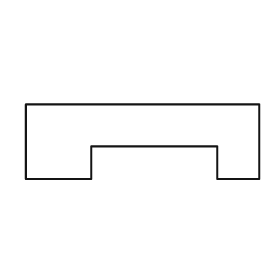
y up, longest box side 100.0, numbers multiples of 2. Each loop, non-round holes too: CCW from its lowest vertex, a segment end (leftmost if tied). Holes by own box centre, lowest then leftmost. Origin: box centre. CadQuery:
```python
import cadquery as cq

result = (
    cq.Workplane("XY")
    .moveTo(-50.0, -16.0)
    .lineTo(-22.0, -16.0)
    .lineTo(-22.0, -2.0)
    .lineTo(32.0, -2.0)
    .lineTo(32.0, -16.0)
    .lineTo(50.0, -16.0)
    .lineTo(50.0, 16.0)
    .lineTo(-50.0, 16.0)
    .close()
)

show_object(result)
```